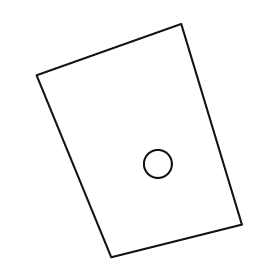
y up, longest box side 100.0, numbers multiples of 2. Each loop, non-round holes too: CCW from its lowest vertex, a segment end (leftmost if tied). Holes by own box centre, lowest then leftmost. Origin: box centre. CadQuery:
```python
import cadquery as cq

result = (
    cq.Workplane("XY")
    .moveTo(-12.0, -50.0)
    .lineTo(44.0, -36.0)
    .lineTo(18.0, 50.0)
    .lineTo(-44.0, 28.0)
    .close()
    .moveTo(8.0, -10.0)
    .circle(6.0)
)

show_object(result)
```